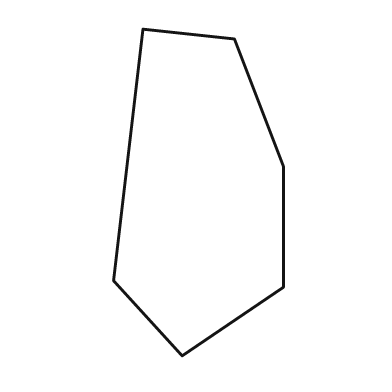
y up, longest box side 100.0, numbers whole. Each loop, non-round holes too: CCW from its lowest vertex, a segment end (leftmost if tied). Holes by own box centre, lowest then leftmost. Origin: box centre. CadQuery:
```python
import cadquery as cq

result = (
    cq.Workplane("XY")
    .moveTo(-5.0, -50.0)
    .lineTo(26.0, -29.0)
    .lineTo(26.0, 8.0)
    .lineTo(11.0, 47.0)
    .lineTo(-17.0, 50.0)
    .lineTo(-26.0, -27.0)
    .close()
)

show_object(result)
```